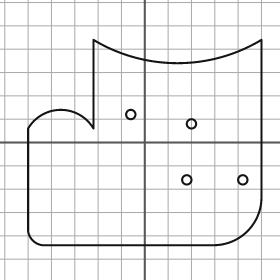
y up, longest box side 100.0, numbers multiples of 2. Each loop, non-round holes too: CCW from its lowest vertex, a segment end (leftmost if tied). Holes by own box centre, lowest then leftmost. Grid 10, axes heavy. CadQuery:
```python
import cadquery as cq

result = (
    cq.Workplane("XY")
    .moveTo(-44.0, -44.0)
    .lineTo(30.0, -44.0)
    .threePointArc((44.0, -38.0), (50.0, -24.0))
    .lineTo(50.0, 44.0)
    .threePointArc((14.0, 34.0), (-22.0, 44.0))
    .lineTo(-22.0, 6.0)
    .threePointArc((-36.0, 14.0), (-50.0, 6.0))
    .lineTo(-50.0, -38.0)
    .threePointArc((-48.0, -42.0), (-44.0, -44.0))
    .close()
    .moveTo(18.0, -16.0)
    .circle(2.0)
    .moveTo(42.0, -16.0)
    .circle(2.0)
    .moveTo(20.0, 8.0)
    .circle(2.0)
    .moveTo(-6.0, 12.0)
    .circle(2.0)
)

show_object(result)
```